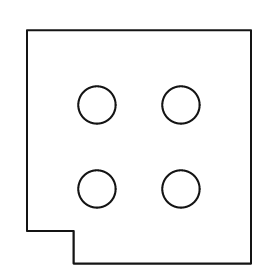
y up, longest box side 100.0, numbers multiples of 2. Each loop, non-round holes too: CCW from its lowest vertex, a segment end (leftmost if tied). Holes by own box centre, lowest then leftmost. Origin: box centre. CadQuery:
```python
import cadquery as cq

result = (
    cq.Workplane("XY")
    .moveTo(-28.0, -50.0)
    .lineTo(48.0, -50.0)
    .lineTo(48.0, 50.0)
    .lineTo(-48.0, 50.0)
    .lineTo(-48.0, -36.0)
    .lineTo(-28.0, -36.0)
    .close()
    .moveTo(-18.0, -18.0)
    .circle(8.0)
    .moveTo(18.0, -18.0)
    .circle(8.0)
    .moveTo(-18.0, 18.0)
    .circle(8.0)
    .moveTo(18.0, 18.0)
    .circle(8.0)
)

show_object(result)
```